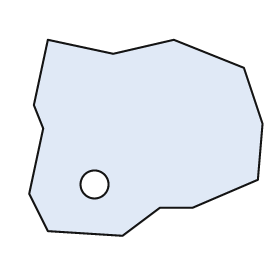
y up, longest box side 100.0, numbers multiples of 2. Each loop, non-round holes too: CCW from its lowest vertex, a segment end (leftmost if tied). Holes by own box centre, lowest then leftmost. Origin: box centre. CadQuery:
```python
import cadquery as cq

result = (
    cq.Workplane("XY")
    .moveTo(-10.0, -42.0)
    .lineTo(6.0, -30.0)
    .lineTo(20.0, -30.0)
    .lineTo(48.0, -18.0)
    .lineTo(50.0, 6.0)
    .lineTo(42.0, 30.0)
    .lineTo(12.0, 42.0)
    .lineTo(-14.0, 36.0)
    .lineTo(-42.0, 42.0)
    .lineTo(-48.0, 14.0)
    .lineTo(-44.0, 4.0)
    .lineTo(-50.0, -24.0)
    .lineTo(-42.0, -40.0)
    .close()
    .moveTo(-22.0, -20.0)
    .circle(6.0)
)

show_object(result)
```